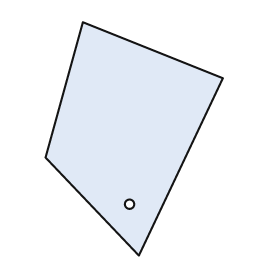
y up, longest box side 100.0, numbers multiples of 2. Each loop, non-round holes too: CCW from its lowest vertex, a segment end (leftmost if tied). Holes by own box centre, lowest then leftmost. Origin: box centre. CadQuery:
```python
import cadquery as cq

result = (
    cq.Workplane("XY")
    .moveTo(2.0, -50.0)
    .lineTo(38.0, 26.0)
    .lineTo(-22.0, 50.0)
    .lineTo(-38.0, -8.0)
    .close()
    .moveTo(-2.0, -28.0)
    .circle(2.0)
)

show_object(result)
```